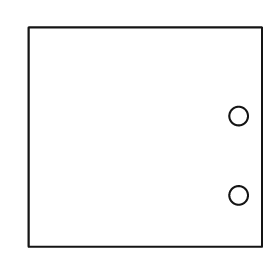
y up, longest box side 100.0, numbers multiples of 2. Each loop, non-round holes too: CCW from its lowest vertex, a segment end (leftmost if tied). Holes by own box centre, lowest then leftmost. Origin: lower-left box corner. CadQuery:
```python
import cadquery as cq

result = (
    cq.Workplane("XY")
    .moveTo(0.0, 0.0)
    .lineTo(100.0, 0.0)
    .lineTo(100.0, 94.0)
    .lineTo(0.0, 94.0)
    .close()
    .moveTo(90.0, 22.0)
    .circle(4.0)
    .moveTo(90.0, 56.0)
    .circle(4.0)
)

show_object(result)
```